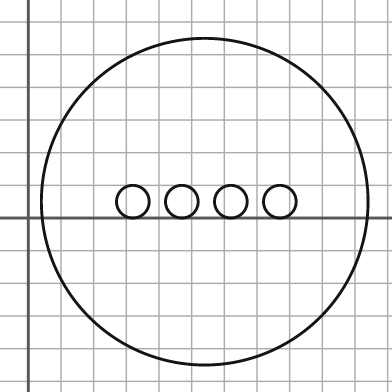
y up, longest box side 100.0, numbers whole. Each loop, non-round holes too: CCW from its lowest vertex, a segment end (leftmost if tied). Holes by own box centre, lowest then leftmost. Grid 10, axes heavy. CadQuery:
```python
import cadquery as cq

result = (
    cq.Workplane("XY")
    .moveTo(54.0, 5.0)
    .circle(50.0)
    .moveTo(32.0, 5.0)
    .circle(5.0)
    .moveTo(47.0, 5.0)
    .circle(5.0)
    .moveTo(62.0, 5.0)
    .circle(5.0)
    .moveTo(77.0, 5.0)
    .circle(5.0)
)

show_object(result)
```